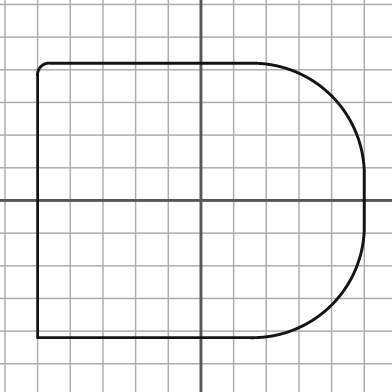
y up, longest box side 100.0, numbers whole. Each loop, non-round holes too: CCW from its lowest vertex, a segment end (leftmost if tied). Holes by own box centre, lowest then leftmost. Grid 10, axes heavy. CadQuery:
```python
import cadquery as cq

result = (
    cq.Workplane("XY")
    .moveTo(-50.0, -42.0)
    .lineTo(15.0, -42.0)
    .threePointArc((40.0, -32.0), (50.0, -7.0))
    .lineTo(50.0, 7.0)
    .threePointArc((40.0, 32.0), (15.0, 42.0))
    .lineTo(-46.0, 42.0)
    .threePointArc((-49.0, 41.0), (-50.0, 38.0))
    .close()
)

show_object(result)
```